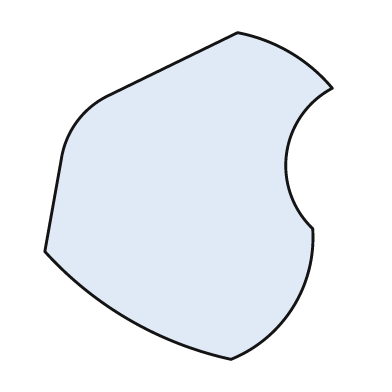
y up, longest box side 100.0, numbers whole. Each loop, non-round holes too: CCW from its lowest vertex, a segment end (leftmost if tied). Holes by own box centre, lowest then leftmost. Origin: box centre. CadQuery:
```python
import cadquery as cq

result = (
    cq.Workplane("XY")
    .moveTo(13.0, -50.0)
    .threePointArc((32.0, -34.0), (38.0, -10.0))
    .threePointArc((30.0, 13.0), (44.0, 33.0))
    .threePointArc((31.0, 44.0), (15.0, 50.0))
    .lineTo(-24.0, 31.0)
    .threePointArc((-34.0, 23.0), (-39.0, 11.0))
    .lineTo(-44.0, -17.0)
    .threePointArc((-18.0, -38.0), (13.0, -50.0))
    .close()
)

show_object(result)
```